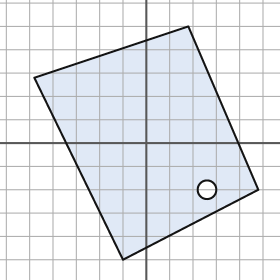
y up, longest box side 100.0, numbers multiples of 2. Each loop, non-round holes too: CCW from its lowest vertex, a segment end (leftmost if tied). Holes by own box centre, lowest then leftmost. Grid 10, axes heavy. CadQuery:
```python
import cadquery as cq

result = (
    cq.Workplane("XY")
    .moveTo(-10.0, -50.0)
    .lineTo(48.0, -20.0)
    .lineTo(18.0, 50.0)
    .lineTo(-48.0, 28.0)
    .close()
    .moveTo(26.0, -20.0)
    .circle(4.0)
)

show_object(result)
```